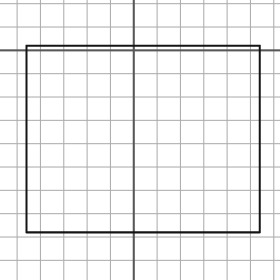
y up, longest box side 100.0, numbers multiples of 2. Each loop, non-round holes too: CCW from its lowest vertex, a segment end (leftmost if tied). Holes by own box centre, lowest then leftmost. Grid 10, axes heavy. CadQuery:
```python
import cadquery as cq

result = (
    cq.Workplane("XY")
    .moveTo(-46.0, -78.0)
    .lineTo(54.0, -78.0)
    .lineTo(54.0, 2.0)
    .lineTo(-46.0, 2.0)
    .close()
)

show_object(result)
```